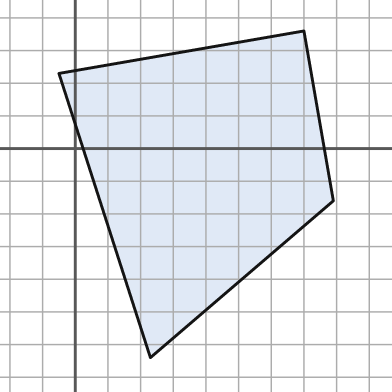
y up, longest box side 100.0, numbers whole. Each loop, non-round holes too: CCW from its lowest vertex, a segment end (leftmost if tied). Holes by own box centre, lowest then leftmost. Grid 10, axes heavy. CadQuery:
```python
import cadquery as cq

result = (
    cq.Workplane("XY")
    .moveTo(23.0, -64.0)
    .lineTo(79.0, -16.0)
    .lineTo(70.0, 36.0)
    .lineTo(-5.0, 23.0)
    .close()
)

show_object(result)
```